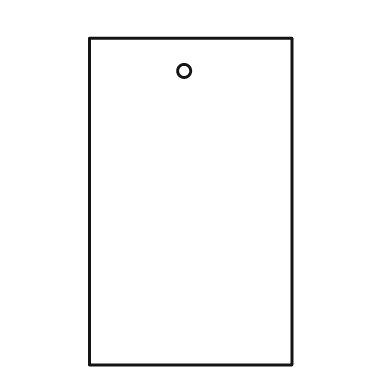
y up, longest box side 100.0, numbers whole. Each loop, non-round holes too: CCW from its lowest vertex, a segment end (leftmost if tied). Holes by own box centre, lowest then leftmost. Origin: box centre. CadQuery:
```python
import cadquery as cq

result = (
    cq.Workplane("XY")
    .moveTo(-31.0, -50.0)
    .lineTo(31.0, -50.0)
    .lineTo(31.0, 50.0)
    .lineTo(-31.0, 50.0)
    .close()
    .moveTo(-2.0, 40.0)
    .circle(2.0)
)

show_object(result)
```